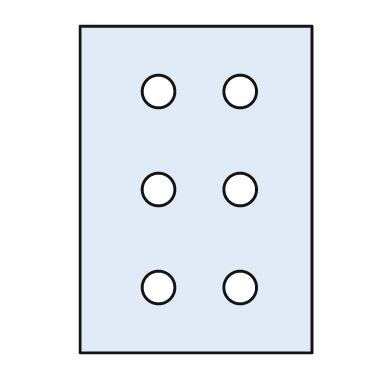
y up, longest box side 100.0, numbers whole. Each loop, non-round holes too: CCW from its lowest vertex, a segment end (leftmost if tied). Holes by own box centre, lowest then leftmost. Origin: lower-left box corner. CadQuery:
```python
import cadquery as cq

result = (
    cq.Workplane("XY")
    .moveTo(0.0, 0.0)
    .lineTo(71.0, 0.0)
    .lineTo(71.0, 100.0)
    .lineTo(0.0, 100.0)
    .close()
    .moveTo(24.0, 20.0)
    .circle(5.0)
    .moveTo(49.0, 20.0)
    .circle(5.0)
    .moveTo(24.0, 50.0)
    .circle(5.0)
    .moveTo(49.0, 50.0)
    .circle(5.0)
    .moveTo(24.0, 80.0)
    .circle(5.0)
    .moveTo(49.0, 80.0)
    .circle(5.0)
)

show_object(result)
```